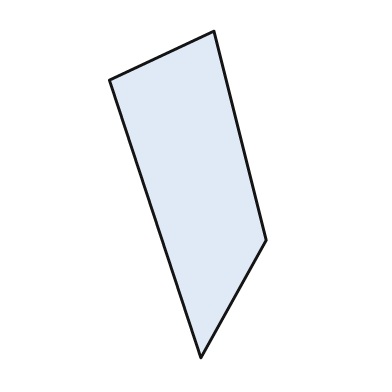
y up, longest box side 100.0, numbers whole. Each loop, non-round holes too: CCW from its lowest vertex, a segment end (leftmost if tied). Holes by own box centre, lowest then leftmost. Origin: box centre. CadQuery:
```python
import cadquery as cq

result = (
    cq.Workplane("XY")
    .moveTo(4.0, -50.0)
    .lineTo(24.0, -14.0)
    .lineTo(8.0, 50.0)
    .lineTo(-24.0, 35.0)
    .close()
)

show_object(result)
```